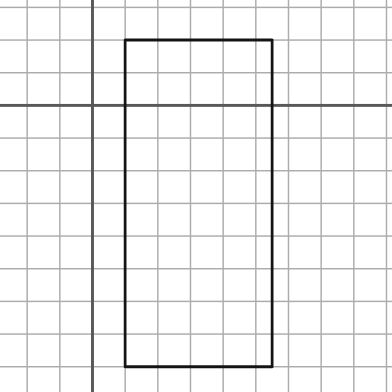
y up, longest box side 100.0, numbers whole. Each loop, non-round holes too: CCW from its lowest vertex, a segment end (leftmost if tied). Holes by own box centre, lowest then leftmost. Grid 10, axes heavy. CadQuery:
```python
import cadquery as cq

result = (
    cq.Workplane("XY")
    .moveTo(10.0, -80.0)
    .lineTo(55.0, -80.0)
    .lineTo(55.0, 20.0)
    .lineTo(10.0, 20.0)
    .close()
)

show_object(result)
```